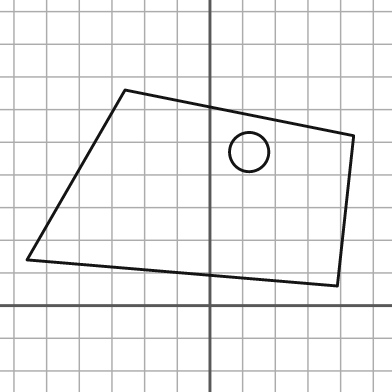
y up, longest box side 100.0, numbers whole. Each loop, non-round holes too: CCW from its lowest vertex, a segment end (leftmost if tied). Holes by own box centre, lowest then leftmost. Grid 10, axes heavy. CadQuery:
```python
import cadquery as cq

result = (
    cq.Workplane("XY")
    .moveTo(39.0, 6.0)
    .lineTo(44.0, 52.0)
    .lineTo(-26.0, 66.0)
    .lineTo(-56.0, 14.0)
    .close()
    .moveTo(12.0, 47.0)
    .circle(6.0)
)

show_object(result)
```